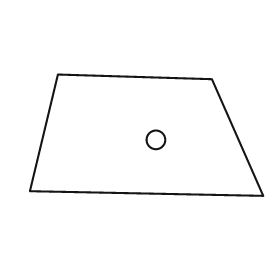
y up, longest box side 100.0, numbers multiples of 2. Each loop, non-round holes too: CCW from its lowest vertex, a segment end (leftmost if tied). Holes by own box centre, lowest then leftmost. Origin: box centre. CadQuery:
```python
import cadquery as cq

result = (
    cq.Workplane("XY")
    .moveTo(50.0, -26.0)
    .lineTo(28.0, 24.0)
    .lineTo(-38.0, 26.0)
    .lineTo(-50.0, -24.0)
    .close()
    .moveTo(4.0, -2.0)
    .circle(4.0)
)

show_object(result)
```